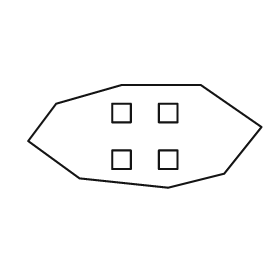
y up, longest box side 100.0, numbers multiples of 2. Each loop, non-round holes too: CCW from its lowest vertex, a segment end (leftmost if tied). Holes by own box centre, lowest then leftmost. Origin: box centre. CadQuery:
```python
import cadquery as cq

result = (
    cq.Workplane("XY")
    .moveTo(10.0, -22.0)
    .lineTo(34.0, -16.0)
    .lineTo(50.0, 4.0)
    .lineTo(24.0, 22.0)
    .lineTo(-10.0, 22.0)
    .lineTo(-38.0, 14.0)
    .lineTo(-50.0, -2.0)
    .lineTo(-28.0, -18.0)
    .close()
    .moveTo(-14.0, -14.0)
    .lineTo(-6.0, -14.0)
    .lineTo(-6.0, -6.0)
    .lineTo(-14.0, -6.0)
    .close()
    .moveTo(6.0, -14.0)
    .lineTo(14.0, -14.0)
    .lineTo(14.0, -6.0)
    .lineTo(6.0, -6.0)
    .close()
    .moveTo(-14.0, 6.0)
    .lineTo(-6.0, 6.0)
    .lineTo(-6.0, 14.0)
    .lineTo(-14.0, 14.0)
    .close()
    .moveTo(6.0, 6.0)
    .lineTo(14.0, 6.0)
    .lineTo(14.0, 14.0)
    .lineTo(6.0, 14.0)
    .close()
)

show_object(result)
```